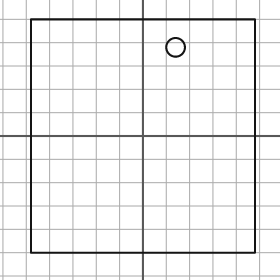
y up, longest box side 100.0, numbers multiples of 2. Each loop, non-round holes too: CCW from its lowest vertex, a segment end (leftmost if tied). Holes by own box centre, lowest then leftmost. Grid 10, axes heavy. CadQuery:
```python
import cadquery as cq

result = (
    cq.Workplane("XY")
    .moveTo(-48.0, -50.0)
    .lineTo(48.0, -50.0)
    .lineTo(48.0, 50.0)
    .lineTo(-48.0, 50.0)
    .close()
    .moveTo(14.0, 38.0)
    .circle(4.0)
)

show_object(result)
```